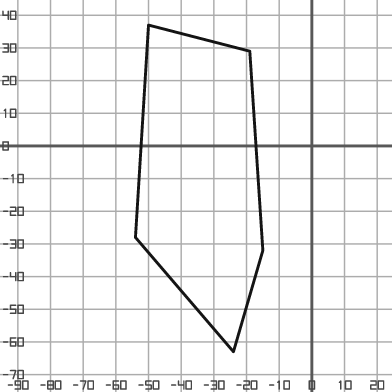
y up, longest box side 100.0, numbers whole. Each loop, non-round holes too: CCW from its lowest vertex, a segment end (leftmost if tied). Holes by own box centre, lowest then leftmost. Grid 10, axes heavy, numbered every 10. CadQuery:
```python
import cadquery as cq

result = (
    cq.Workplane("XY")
    .moveTo(-24.0, -63.0)
    .lineTo(-15.0, -32.0)
    .lineTo(-19.0, 29.0)
    .lineTo(-50.0, 37.0)
    .lineTo(-54.0, -28.0)
    .close()
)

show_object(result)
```